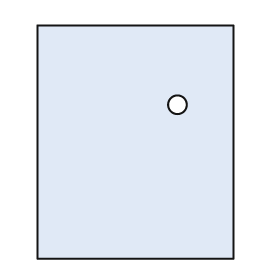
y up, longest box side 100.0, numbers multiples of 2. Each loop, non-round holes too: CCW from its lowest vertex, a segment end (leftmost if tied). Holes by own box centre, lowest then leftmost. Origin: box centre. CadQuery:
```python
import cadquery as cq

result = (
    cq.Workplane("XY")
    .moveTo(-42.0, -50.0)
    .lineTo(42.0, -50.0)
    .lineTo(42.0, 50.0)
    .lineTo(-42.0, 50.0)
    .close()
    .moveTo(18.0, 16.0)
    .circle(4.0)
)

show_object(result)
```